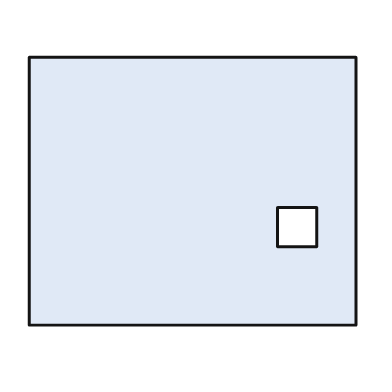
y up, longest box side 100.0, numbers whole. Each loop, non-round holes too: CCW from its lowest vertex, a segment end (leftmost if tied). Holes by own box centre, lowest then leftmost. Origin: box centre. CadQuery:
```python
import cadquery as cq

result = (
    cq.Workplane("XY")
    .moveTo(-50.0, -41.0)
    .lineTo(50.0, -41.0)
    .lineTo(50.0, 41.0)
    .lineTo(-50.0, 41.0)
    .close()
    .moveTo(26.0, -17.0)
    .lineTo(38.0, -17.0)
    .lineTo(38.0, -5.0)
    .lineTo(26.0, -5.0)
    .close()
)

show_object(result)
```